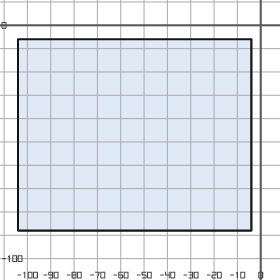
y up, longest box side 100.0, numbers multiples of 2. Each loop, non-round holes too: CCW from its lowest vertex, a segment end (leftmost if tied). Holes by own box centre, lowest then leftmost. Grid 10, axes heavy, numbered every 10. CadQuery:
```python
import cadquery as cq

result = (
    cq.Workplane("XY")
    .moveTo(-104.0, -88.0)
    .lineTo(-4.0, -88.0)
    .lineTo(-4.0, -6.0)
    .lineTo(-104.0, -6.0)
    .close()
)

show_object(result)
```